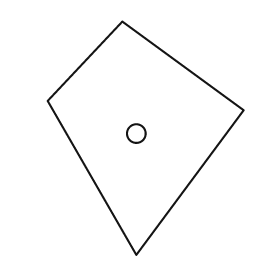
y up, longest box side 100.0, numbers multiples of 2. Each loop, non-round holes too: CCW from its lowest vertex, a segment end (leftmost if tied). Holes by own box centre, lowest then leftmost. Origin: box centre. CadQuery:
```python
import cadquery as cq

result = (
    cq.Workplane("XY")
    .moveTo(-4.0, -50.0)
    .lineTo(42.0, 12.0)
    .lineTo(-10.0, 50.0)
    .lineTo(-42.0, 16.0)
    .close()
    .moveTo(-4.0, 2.0)
    .circle(4.0)
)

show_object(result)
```